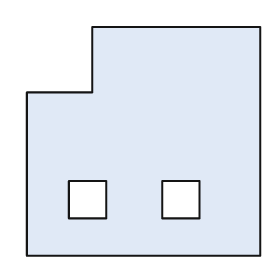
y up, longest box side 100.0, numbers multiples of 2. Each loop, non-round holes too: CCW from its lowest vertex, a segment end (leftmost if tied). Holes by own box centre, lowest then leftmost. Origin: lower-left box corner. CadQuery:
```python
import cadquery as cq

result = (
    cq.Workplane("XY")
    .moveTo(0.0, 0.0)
    .lineTo(100.0, 0.0)
    .lineTo(100.0, 98.0)
    .lineTo(28.0, 98.0)
    .lineTo(28.0, 70.0)
    .lineTo(0.0, 70.0)
    .close()
    .moveTo(18.0, 16.0)
    .lineTo(34.0, 16.0)
    .lineTo(34.0, 32.0)
    .lineTo(18.0, 32.0)
    .close()
    .moveTo(58.0, 16.0)
    .lineTo(74.0, 16.0)
    .lineTo(74.0, 32.0)
    .lineTo(58.0, 32.0)
    .close()
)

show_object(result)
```